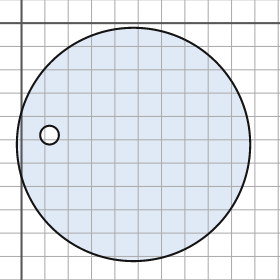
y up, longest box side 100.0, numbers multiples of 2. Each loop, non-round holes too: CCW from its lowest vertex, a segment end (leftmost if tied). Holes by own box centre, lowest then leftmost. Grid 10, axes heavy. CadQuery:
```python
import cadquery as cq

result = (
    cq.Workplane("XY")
    .moveTo(48.0, -52.0)
    .circle(50.0)
    .moveTo(12.0, -48.0)
    .circle(4.0)
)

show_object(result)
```